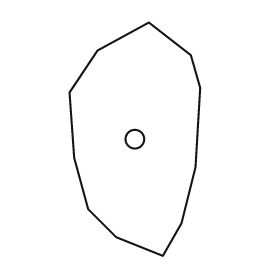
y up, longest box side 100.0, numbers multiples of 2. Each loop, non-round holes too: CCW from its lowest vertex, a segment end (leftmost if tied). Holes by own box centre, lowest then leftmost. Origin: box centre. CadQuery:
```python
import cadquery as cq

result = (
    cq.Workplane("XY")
    .moveTo(12.0, -50.0)
    .lineTo(20.0, -36.0)
    .lineTo(26.0, -12.0)
    .lineTo(28.0, 22.0)
    .lineTo(24.0, 36.0)
    .lineTo(6.0, 50.0)
    .lineTo(-16.0, 38.0)
    .lineTo(-28.0, 20.0)
    .lineTo(-26.0, -8.0)
    .lineTo(-20.0, -30.0)
    .lineTo(-8.0, -42.0)
    .close()
    .moveTo(0.0, 0.0)
    .circle(4.0)
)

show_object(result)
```